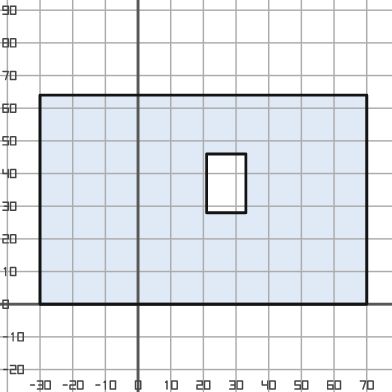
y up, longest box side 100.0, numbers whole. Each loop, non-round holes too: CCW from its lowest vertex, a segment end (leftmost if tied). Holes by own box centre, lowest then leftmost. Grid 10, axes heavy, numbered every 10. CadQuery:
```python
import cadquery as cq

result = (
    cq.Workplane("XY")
    .moveTo(-30.0, 0.0)
    .lineTo(70.0, 0.0)
    .lineTo(70.0, 64.0)
    .lineTo(-30.0, 64.0)
    .close()
    .moveTo(21.0, 28.0)
    .lineTo(33.0, 28.0)
    .lineTo(33.0, 46.0)
    .lineTo(21.0, 46.0)
    .close()
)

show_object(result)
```